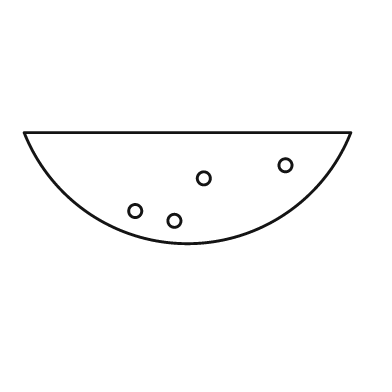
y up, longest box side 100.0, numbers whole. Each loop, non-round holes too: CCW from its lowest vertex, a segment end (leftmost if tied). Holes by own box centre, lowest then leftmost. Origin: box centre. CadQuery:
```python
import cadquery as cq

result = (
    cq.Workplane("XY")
    .moveTo(-50.0, 17.0)
    .threePointArc((0.0, -17.0), (50.0, 17.0))
    .close()
    .moveTo(-4.0, -10.0)
    .circle(2.0)
    .moveTo(-16.0, -7.0)
    .circle(2.0)
    .moveTo(5.0, 3.0)
    .circle(2.0)
    .moveTo(30.0, 7.0)
    .circle(2.0)
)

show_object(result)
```